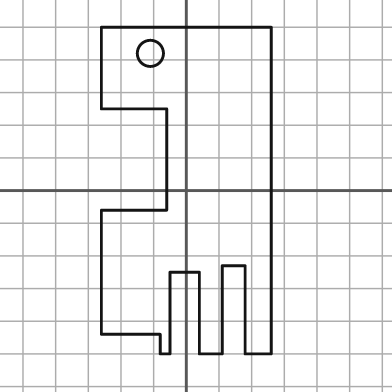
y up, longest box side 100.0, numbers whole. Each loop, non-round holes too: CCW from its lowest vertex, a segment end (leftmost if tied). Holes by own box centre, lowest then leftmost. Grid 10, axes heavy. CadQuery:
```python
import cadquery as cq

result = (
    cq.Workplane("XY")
    .moveTo(-8.0, -50.0)
    .lineTo(-5.0, -50.0)
    .lineTo(-5.0, -25.0)
    .lineTo(4.0, -25.0)
    .lineTo(4.0, -50.0)
    .lineTo(11.0, -50.0)
    .lineTo(11.0, -23.0)
    .lineTo(18.0, -23.0)
    .lineTo(18.0, -50.0)
    .lineTo(26.0, -50.0)
    .lineTo(26.0, 50.0)
    .lineTo(-26.0, 50.0)
    .lineTo(-26.0, 25.0)
    .lineTo(-6.0, 25.0)
    .lineTo(-6.0, -6.0)
    .lineTo(-26.0, -6.0)
    .lineTo(-26.0, -44.0)
    .lineTo(-8.0, -44.0)
    .close()
    .moveTo(-11.0, 42.0)
    .circle(4.0)
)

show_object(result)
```